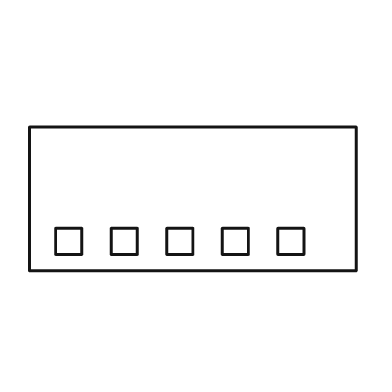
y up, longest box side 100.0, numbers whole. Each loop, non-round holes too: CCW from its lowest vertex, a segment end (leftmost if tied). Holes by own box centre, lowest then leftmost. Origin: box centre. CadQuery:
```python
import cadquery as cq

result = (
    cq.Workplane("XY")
    .moveTo(-50.0, -22.0)
    .lineTo(50.0, -22.0)
    .lineTo(50.0, 22.0)
    .lineTo(-50.0, 22.0)
    .close()
    .moveTo(-42.0, -17.0)
    .lineTo(-34.0, -17.0)
    .lineTo(-34.0, -9.0)
    .lineTo(-42.0, -9.0)
    .close()
    .moveTo(-25.0, -17.0)
    .lineTo(-17.0, -17.0)
    .lineTo(-17.0, -9.0)
    .lineTo(-25.0, -9.0)
    .close()
    .moveTo(-8.0, -17.0)
    .lineTo(0.0, -17.0)
    .lineTo(0.0, -9.0)
    .lineTo(-8.0, -9.0)
    .close()
    .moveTo(9.0, -17.0)
    .lineTo(17.0, -17.0)
    .lineTo(17.0, -9.0)
    .lineTo(9.0, -9.0)
    .close()
    .moveTo(26.0, -17.0)
    .lineTo(34.0, -17.0)
    .lineTo(34.0, -9.0)
    .lineTo(26.0, -9.0)
    .close()
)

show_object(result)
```